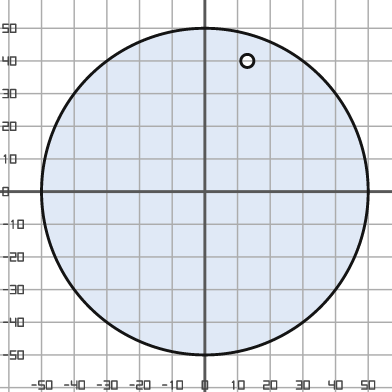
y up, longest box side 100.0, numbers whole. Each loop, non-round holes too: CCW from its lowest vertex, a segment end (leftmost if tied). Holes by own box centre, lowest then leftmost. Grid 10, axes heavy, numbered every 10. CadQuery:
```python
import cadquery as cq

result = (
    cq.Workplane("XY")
    .moveTo(0.0, 0.0)
    .circle(50.0)
    .moveTo(13.0, 40.0)
    .circle(2.0)
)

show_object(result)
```